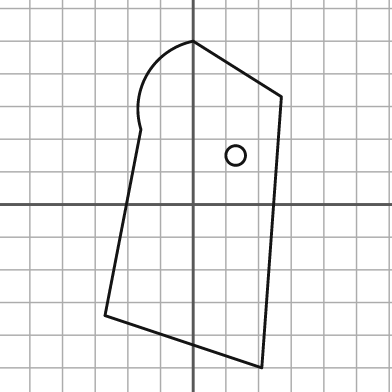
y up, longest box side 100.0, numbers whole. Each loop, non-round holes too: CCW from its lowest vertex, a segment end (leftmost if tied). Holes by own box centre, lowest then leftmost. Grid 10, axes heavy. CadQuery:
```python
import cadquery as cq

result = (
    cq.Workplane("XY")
    .moveTo(21.0, -50.0)
    .lineTo(27.0, 33.0)
    .lineTo(0.0, 50.0)
    .threePointArc((-14.0, 40.0), (-16.0, 23.0))
    .lineTo(-27.0, -34.0)
    .close()
    .moveTo(13.0, 15.0)
    .circle(3.0)
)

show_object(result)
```